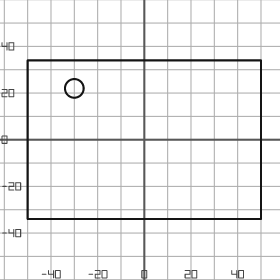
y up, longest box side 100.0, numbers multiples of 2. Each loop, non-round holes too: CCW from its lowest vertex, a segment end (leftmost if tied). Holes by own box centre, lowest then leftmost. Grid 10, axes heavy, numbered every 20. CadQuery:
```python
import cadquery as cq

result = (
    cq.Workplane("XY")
    .moveTo(-50.0, -34.0)
    .lineTo(50.0, -34.0)
    .lineTo(50.0, 34.0)
    .lineTo(-50.0, 34.0)
    .close()
    .moveTo(-30.0, 22.0)
    .circle(4.0)
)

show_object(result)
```